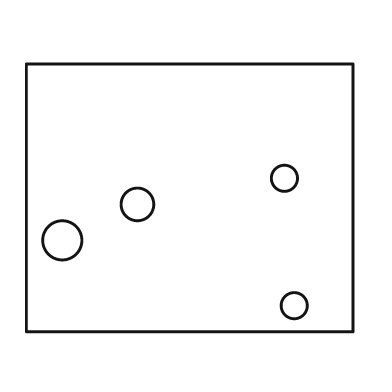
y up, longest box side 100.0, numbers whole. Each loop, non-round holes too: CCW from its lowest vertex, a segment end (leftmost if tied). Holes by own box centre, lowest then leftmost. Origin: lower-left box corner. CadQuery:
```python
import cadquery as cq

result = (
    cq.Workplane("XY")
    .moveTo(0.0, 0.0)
    .lineTo(100.0, 0.0)
    .lineTo(100.0, 82.0)
    .lineTo(0.0, 82.0)
    .close()
    .moveTo(82.0, 8.0)
    .circle(4.0)
    .moveTo(11.0, 28.0)
    .circle(6.0)
    .moveTo(34.0, 39.0)
    .circle(5.0)
    .moveTo(79.0, 47.0)
    .circle(4.0)
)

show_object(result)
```